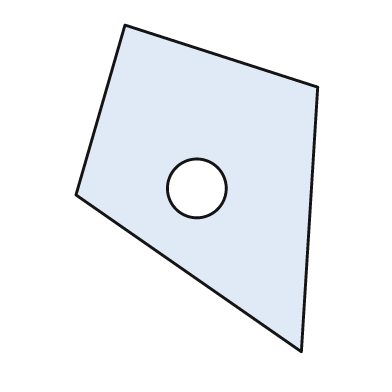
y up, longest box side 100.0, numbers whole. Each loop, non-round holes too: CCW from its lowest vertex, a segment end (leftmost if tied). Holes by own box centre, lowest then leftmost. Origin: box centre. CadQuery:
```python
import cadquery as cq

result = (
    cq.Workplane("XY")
    .moveTo(32.0, -50.0)
    .lineTo(37.0, 31.0)
    .lineTo(-22.0, 50.0)
    .lineTo(-37.0, -2.0)
    .close()
    .moveTo(0.0, 0.0)
    .circle(9.0)
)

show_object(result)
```